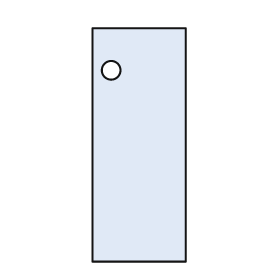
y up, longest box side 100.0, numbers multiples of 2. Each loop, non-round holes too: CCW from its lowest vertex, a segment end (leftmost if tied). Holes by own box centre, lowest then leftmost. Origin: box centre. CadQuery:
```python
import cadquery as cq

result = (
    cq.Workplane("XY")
    .moveTo(-20.0, -50.0)
    .lineTo(20.0, -50.0)
    .lineTo(20.0, 50.0)
    .lineTo(-20.0, 50.0)
    .close()
    .moveTo(-12.0, 32.0)
    .circle(4.0)
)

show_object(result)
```